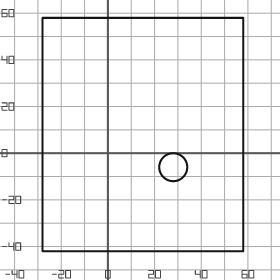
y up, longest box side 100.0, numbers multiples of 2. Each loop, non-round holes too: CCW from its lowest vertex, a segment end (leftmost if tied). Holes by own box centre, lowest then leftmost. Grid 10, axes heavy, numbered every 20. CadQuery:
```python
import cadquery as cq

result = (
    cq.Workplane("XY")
    .moveTo(-28.0, -42.0)
    .lineTo(58.0, -42.0)
    .lineTo(58.0, 58.0)
    .lineTo(-28.0, 58.0)
    .close()
    .moveTo(28.0, -6.0)
    .circle(6.0)
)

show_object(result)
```